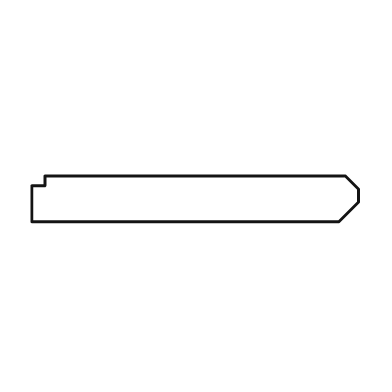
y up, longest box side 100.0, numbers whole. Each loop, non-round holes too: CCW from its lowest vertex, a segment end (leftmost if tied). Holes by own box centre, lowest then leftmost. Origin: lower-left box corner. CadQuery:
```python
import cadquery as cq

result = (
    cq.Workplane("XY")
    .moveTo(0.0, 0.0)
    .lineTo(94.0, 0.0)
    .lineTo(100.0, 6.0)
    .lineTo(100.0, 10.0)
    .lineTo(96.0, 14.0)
    .lineTo(4.0, 14.0)
    .lineTo(4.0, 11.0)
    .lineTo(0.0, 11.0)
    .close()
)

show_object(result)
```